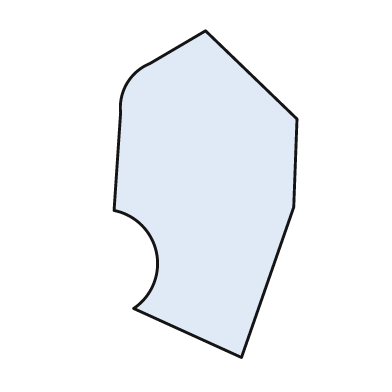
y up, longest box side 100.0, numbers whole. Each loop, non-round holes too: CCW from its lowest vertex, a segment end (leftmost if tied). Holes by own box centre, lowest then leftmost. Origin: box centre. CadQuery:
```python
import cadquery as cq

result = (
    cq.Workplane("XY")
    .moveTo(11.0, -50.0)
    .lineTo(27.0, -4.0)
    .lineTo(28.0, 23.0)
    .lineTo(0.0, 50.0)
    .lineTo(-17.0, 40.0)
    .threePointArc((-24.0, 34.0), (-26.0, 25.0))
    .lineTo(-28.0, -5.0)
    .threePointArc((-15.0, -18.0), (-22.0, -35.0))
    .close()
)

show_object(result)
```